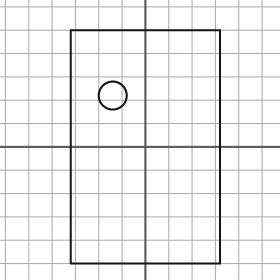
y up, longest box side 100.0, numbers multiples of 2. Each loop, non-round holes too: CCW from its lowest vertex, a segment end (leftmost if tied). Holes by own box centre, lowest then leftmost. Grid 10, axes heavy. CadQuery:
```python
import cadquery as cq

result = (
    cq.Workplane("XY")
    .moveTo(-32.0, -50.0)
    .lineTo(32.0, -50.0)
    .lineTo(32.0, 50.0)
    .lineTo(-32.0, 50.0)
    .close()
    .moveTo(-14.0, 22.0)
    .circle(6.0)
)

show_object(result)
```